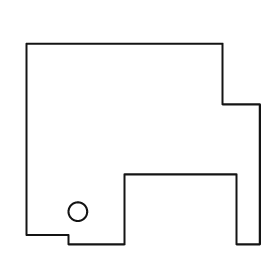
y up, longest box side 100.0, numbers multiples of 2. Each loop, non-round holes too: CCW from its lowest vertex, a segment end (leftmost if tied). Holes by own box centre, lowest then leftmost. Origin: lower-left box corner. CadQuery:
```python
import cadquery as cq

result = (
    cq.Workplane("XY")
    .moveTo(18.0, 0.0)
    .lineTo(42.0, 0.0)
    .lineTo(42.0, 30.0)
    .lineTo(90.0, 30.0)
    .lineTo(90.0, 0.0)
    .lineTo(100.0, 0.0)
    .lineTo(100.0, 60.0)
    .lineTo(84.0, 60.0)
    .lineTo(84.0, 86.0)
    .lineTo(0.0, 86.0)
    .lineTo(0.0, 4.0)
    .lineTo(18.0, 4.0)
    .close()
    .moveTo(22.0, 14.0)
    .circle(4.0)
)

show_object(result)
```